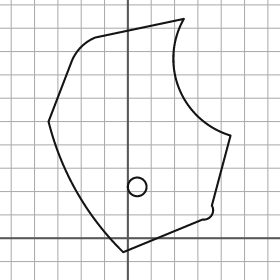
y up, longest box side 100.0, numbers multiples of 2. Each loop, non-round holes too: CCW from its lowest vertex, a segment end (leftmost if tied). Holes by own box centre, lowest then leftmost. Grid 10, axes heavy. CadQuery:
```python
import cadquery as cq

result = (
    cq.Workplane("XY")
    .moveTo(-2.0, -6.0)
    .lineTo(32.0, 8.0)
    .threePointArc((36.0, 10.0), (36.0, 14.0))
    .lineTo(44.0, 44.0)
    .threePointArc((22.0, 64.0), (24.0, 94.0))
    .lineTo(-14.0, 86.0)
    .threePointArc((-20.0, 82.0), (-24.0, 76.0))
    .lineTo(-34.0, 50.0)
    .threePointArc((-22.0, 20.0), (-2.0, -6.0))
    .close()
    .moveTo(4.0, 22.0)
    .circle(4.0)
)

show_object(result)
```